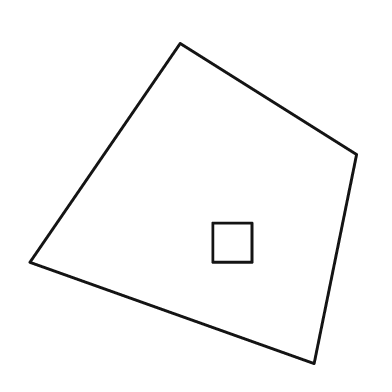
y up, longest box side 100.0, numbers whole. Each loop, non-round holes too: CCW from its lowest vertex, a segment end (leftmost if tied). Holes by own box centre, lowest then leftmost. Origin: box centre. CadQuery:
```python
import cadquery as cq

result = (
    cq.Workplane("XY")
    .moveTo(37.0, -49.0)
    .lineTo(50.0, 15.0)
    .lineTo(-4.0, 49.0)
    .lineTo(-50.0, -18.0)
    .close()
    .moveTo(6.0, -18.0)
    .lineTo(18.0, -18.0)
    .lineTo(18.0, -6.0)
    .lineTo(6.0, -6.0)
    .close()
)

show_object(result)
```